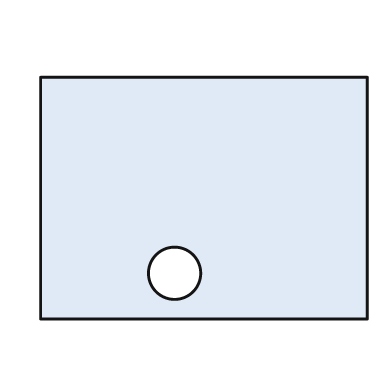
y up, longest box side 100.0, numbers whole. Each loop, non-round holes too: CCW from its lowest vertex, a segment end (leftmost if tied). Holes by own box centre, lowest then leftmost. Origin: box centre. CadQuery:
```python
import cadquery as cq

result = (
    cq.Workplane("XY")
    .moveTo(-50.0, -37.0)
    .lineTo(50.0, -37.0)
    .lineTo(50.0, 37.0)
    .lineTo(-50.0, 37.0)
    .close()
    .moveTo(-9.0, -23.0)
    .circle(8.0)
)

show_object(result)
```